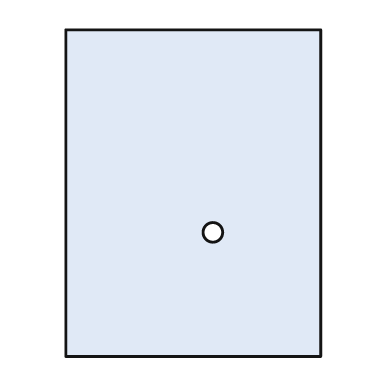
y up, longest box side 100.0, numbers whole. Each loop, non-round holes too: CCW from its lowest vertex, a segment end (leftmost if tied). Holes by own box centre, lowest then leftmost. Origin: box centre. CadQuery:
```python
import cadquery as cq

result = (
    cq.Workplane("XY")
    .moveTo(-39.0, -50.0)
    .lineTo(39.0, -50.0)
    .lineTo(39.0, 50.0)
    .lineTo(-39.0, 50.0)
    .close()
    .moveTo(6.0, -12.0)
    .circle(3.0)
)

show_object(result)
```